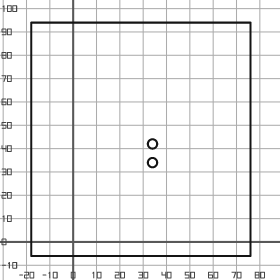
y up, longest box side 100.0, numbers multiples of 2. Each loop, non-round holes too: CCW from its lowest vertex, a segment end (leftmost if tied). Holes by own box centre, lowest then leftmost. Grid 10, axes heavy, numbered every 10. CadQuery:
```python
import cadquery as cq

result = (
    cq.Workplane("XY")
    .moveTo(-18.0, -6.0)
    .lineTo(76.0, -6.0)
    .lineTo(76.0, 94.0)
    .lineTo(-18.0, 94.0)
    .close()
    .moveTo(34.0, 34.0)
    .circle(2.0)
    .moveTo(34.0, 42.0)
    .circle(2.0)
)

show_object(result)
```